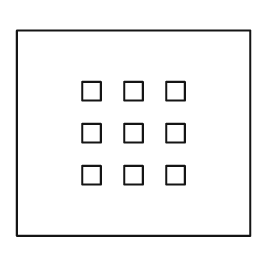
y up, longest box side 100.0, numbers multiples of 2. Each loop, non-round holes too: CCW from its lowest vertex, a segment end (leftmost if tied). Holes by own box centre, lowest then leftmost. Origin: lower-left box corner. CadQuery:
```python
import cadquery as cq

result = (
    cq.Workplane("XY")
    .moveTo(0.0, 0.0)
    .lineTo(100.0, 0.0)
    .lineTo(100.0, 88.0)
    .lineTo(0.0, 88.0)
    .close()
    .moveTo(28.0, 22.0)
    .lineTo(36.0, 22.0)
    .lineTo(36.0, 30.0)
    .lineTo(28.0, 30.0)
    .close()
    .moveTo(46.0, 22.0)
    .lineTo(54.0, 22.0)
    .lineTo(54.0, 30.0)
    .lineTo(46.0, 30.0)
    .close()
    .moveTo(64.0, 22.0)
    .lineTo(72.0, 22.0)
    .lineTo(72.0, 30.0)
    .lineTo(64.0, 30.0)
    .close()
    .moveTo(28.0, 40.0)
    .lineTo(36.0, 40.0)
    .lineTo(36.0, 48.0)
    .lineTo(28.0, 48.0)
    .close()
    .moveTo(46.0, 40.0)
    .lineTo(54.0, 40.0)
    .lineTo(54.0, 48.0)
    .lineTo(46.0, 48.0)
    .close()
    .moveTo(64.0, 40.0)
    .lineTo(72.0, 40.0)
    .lineTo(72.0, 48.0)
    .lineTo(64.0, 48.0)
    .close()
    .moveTo(28.0, 58.0)
    .lineTo(36.0, 58.0)
    .lineTo(36.0, 66.0)
    .lineTo(28.0, 66.0)
    .close()
    .moveTo(46.0, 58.0)
    .lineTo(54.0, 58.0)
    .lineTo(54.0, 66.0)
    .lineTo(46.0, 66.0)
    .close()
    .moveTo(64.0, 58.0)
    .lineTo(72.0, 58.0)
    .lineTo(72.0, 66.0)
    .lineTo(64.0, 66.0)
    .close()
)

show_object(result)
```